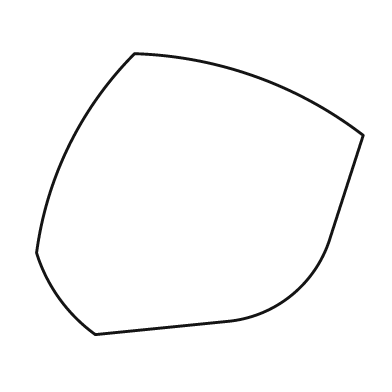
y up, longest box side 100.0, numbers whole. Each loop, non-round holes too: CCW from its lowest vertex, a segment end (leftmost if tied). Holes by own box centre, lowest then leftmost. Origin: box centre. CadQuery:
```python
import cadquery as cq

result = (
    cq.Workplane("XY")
    .moveTo(-32.0, -43.0)
    .lineTo(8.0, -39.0)
    .threePointArc((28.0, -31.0), (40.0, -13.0))
    .lineTo(50.0, 18.0)
    .threePointArc((17.0, 36.0), (-20.0, 43.0))
    .threePointArc((-40.0, 15.0), (-50.0, -18.0))
    .threePointArc((-43.0, -32.0), (-32.0, -43.0))
    .close()
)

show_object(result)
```